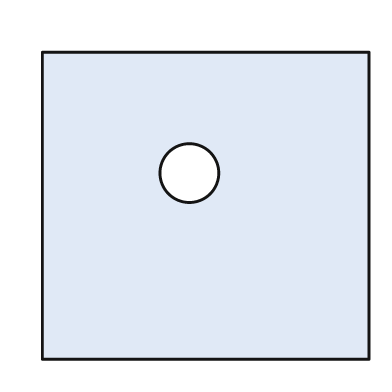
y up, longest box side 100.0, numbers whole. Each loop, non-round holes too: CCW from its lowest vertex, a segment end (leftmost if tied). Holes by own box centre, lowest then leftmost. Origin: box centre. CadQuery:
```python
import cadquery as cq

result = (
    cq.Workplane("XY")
    .moveTo(-50.0, -47.0)
    .lineTo(50.0, -47.0)
    .lineTo(50.0, 47.0)
    .lineTo(-50.0, 47.0)
    .close()
    .moveTo(-5.0, 10.0)
    .circle(9.0)
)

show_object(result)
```